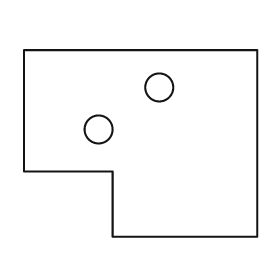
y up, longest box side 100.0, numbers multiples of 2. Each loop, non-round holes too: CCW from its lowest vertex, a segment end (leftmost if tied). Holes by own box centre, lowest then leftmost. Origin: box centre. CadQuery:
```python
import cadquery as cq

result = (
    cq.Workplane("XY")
    .moveTo(-12.0, -40.0)
    .lineTo(50.0, -40.0)
    .lineTo(50.0, 40.0)
    .lineTo(-50.0, 40.0)
    .lineTo(-50.0, -12.0)
    .lineTo(-12.0, -12.0)
    .close()
    .moveTo(-18.0, 6.0)
    .circle(6.0)
    .moveTo(8.0, 24.0)
    .circle(6.0)
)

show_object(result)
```